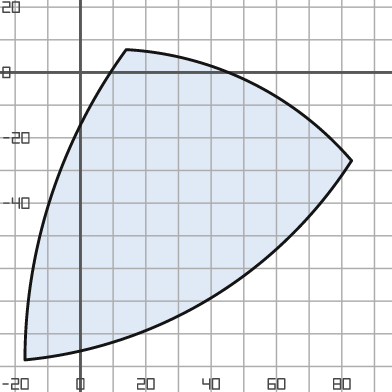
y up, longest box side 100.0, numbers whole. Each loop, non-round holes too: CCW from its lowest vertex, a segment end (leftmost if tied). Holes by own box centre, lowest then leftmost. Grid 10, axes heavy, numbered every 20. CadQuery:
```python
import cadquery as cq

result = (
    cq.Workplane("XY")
    .moveTo(-17.0, -88.0)
    .threePointArc((40.0, -69.0), (83.0, -27.0))
    .threePointArc((52.0, -3.0), (14.0, 7.0))
    .threePointArc((-9.0, -38.0), (-17.0, -88.0))
    .close()
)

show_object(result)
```